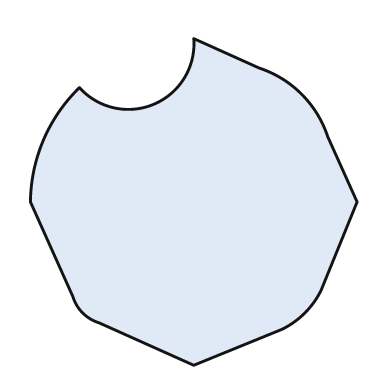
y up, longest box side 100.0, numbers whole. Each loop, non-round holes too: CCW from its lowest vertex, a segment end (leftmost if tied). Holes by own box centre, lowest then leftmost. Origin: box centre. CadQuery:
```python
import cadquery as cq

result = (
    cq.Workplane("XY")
    .moveTo(0.0, -50.0)
    .lineTo(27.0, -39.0)
    .threePointArc((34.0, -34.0), (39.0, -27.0))
    .lineTo(50.0, 0.0)
    .lineTo(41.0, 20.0)
    .threePointArc((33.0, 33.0), (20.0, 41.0))
    .lineTo(0.0, 50.0)
    .threePointArc((-12.0, 30.0), (-35.0, 35.0))
    .threePointArc((-46.0, 19.0), (-50.0, 0.0))
    .lineTo(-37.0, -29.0)
    .threePointArc((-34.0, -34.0), (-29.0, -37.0))
    .close()
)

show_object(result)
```